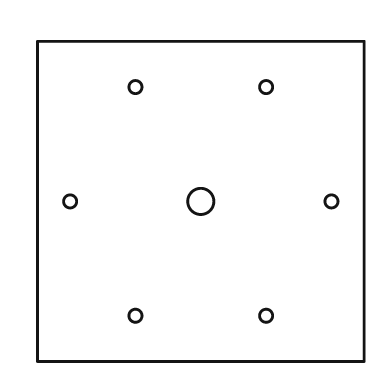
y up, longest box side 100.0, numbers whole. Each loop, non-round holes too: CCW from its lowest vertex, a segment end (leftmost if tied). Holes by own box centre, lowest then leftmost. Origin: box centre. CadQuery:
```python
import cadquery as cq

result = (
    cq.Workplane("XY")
    .moveTo(-50.0, -49.0)
    .lineTo(50.0, -49.0)
    .lineTo(50.0, 49.0)
    .lineTo(-50.0, 49.0)
    .close()
    .moveTo(-20.0, -35.0)
    .circle(2.0)
    .moveTo(20.0, -35.0)
    .circle(2.0)
    .moveTo(-40.0, 0.0)
    .circle(2.0)
    .moveTo(0.0, 0.0)
    .circle(4.0)
    .moveTo(40.0, 0.0)
    .circle(2.0)
    .moveTo(-20.0, 35.0)
    .circle(2.0)
    .moveTo(20.0, 35.0)
    .circle(2.0)
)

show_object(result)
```